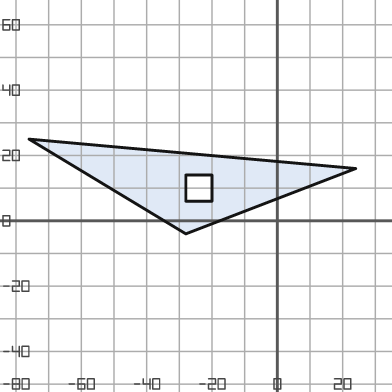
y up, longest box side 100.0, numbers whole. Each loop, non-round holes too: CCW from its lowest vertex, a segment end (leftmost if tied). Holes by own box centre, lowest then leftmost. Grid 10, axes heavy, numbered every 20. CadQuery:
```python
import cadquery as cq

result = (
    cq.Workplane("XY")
    .moveTo(-28.0, -4.0)
    .lineTo(24.0, 16.0)
    .lineTo(-76.0, 25.0)
    .close()
    .moveTo(-28.0, 6.0)
    .lineTo(-20.0, 6.0)
    .lineTo(-20.0, 14.0)
    .lineTo(-28.0, 14.0)
    .close()
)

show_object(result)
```